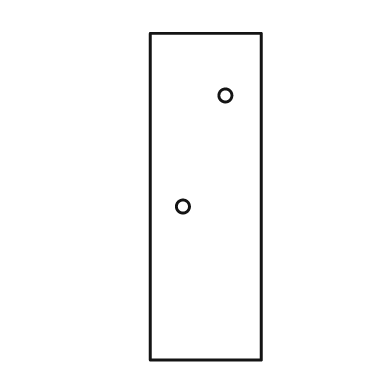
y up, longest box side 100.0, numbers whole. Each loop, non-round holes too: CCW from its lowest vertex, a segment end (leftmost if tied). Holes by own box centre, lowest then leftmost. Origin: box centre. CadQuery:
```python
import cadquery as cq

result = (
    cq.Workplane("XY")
    .moveTo(-17.0, -50.0)
    .lineTo(17.0, -50.0)
    .lineTo(17.0, 50.0)
    .lineTo(-17.0, 50.0)
    .close()
    .moveTo(-7.0, -3.0)
    .circle(2.0)
    .moveTo(6.0, 31.0)
    .circle(2.0)
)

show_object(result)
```